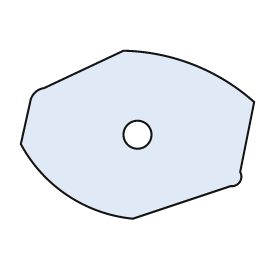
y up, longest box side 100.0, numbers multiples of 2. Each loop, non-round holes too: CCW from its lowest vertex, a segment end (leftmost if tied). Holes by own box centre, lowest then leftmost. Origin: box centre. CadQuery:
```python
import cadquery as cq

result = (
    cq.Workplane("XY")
    .moveTo(-2.0, -36.0)
    .lineTo(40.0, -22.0)
    .threePointArc((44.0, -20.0), (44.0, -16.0))
    .lineTo(50.0, 14.0)
    .threePointArc((24.0, 30.0), (-6.0, 36.0))
    .lineTo(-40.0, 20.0)
    .threePointArc((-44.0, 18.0), (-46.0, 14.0))
    .lineTo(-50.0, -4.0)
    .threePointArc((-30.0, -26.0), (-2.0, -36.0))
    .close()
    .moveTo(0.0, 0.0)
    .circle(6.0)
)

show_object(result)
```